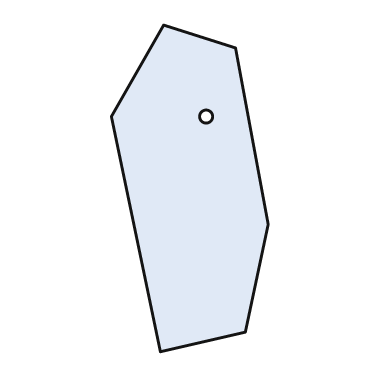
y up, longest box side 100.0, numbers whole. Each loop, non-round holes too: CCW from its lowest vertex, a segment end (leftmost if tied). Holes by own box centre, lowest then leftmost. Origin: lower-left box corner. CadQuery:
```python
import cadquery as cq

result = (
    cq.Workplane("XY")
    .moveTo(15.0, 0.0)
    .lineTo(41.0, 6.0)
    .lineTo(48.0, 39.0)
    .lineTo(38.0, 93.0)
    .lineTo(16.0, 100.0)
    .lineTo(0.0, 72.0)
    .close()
    .moveTo(29.0, 72.0)
    .circle(2.0)
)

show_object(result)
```